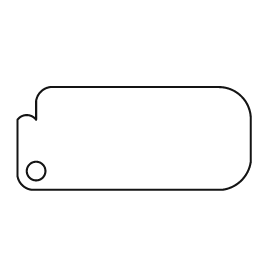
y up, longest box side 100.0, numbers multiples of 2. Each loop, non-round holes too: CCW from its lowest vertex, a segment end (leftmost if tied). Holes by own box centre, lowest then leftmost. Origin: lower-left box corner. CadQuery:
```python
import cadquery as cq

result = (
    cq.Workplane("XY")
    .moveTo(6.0, 0.0)
    .lineTo(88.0, 0.0)
    .threePointArc((96.0, 4.0), (100.0, 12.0))
    .lineTo(100.0, 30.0)
    .threePointArc((96.0, 40.0), (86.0, 44.0))
    .lineTo(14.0, 44.0)
    .threePointArc((10.0, 42.0), (8.0, 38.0))
    .lineTo(8.0, 30.0)
    .threePointArc((4.0, 32.0), (0.0, 30.0))
    .lineTo(0.0, 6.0)
    .threePointArc((2.0, 2.0), (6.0, 0.0))
    .close()
    .moveTo(8.0, 8.0)
    .circle(4.0)
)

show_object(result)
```